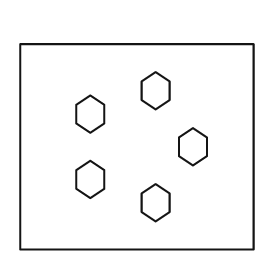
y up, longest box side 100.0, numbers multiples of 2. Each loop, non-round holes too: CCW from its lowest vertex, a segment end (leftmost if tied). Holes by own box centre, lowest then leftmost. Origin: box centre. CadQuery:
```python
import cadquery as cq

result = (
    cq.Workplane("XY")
    .moveTo(-50.0, -44.0)
    .lineTo(50.0, -44.0)
    .lineTo(50.0, 44.0)
    .lineTo(-50.0, 44.0)
    .close()
    .moveTo(8.0, -32.0)
    .lineTo(14.0, -28.0)
    .lineTo(14.0, -20.0)
    .lineTo(8.0, -16.0)
    .lineTo(2.0, -20.0)
    .lineTo(2.0, -28.0)
    .close()
    .moveTo(-20.0, -22.0)
    .lineTo(-14.0, -18.0)
    .lineTo(-14.0, -10.0)
    .lineTo(-20.0, -6.0)
    .lineTo(-26.0, -10.0)
    .lineTo(-26.0, -18.0)
    .close()
    .moveTo(24.0, -8.0)
    .lineTo(30.0, -4.0)
    .lineTo(30.0, 4.0)
    .lineTo(24.0, 8.0)
    .lineTo(18.0, 4.0)
    .lineTo(18.0, -4.0)
    .close()
    .moveTo(-20.0, 6.0)
    .lineTo(-14.0, 10.0)
    .lineTo(-14.0, 18.0)
    .lineTo(-20.0, 22.0)
    .lineTo(-26.0, 18.0)
    .lineTo(-26.0, 10.0)
    .close()
    .moveTo(8.0, 16.0)
    .lineTo(14.0, 20.0)
    .lineTo(14.0, 28.0)
    .lineTo(8.0, 32.0)
    .lineTo(2.0, 28.0)
    .lineTo(2.0, 20.0)
    .close()
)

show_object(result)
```